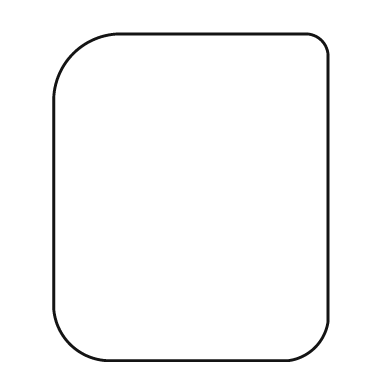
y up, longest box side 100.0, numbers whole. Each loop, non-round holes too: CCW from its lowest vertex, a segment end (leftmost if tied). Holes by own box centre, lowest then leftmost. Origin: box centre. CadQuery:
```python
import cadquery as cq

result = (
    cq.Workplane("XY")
    .moveTo(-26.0, -50.0)
    .lineTo(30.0, -50.0)
    .threePointArc((38.0, -46.0), (42.0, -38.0))
    .lineTo(42.0, 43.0)
    .threePointArc((40.0, 48.0), (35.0, 50.0))
    .lineTo(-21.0, 50.0)
    .threePointArc((-36.0, 44.0), (-42.0, 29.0))
    .lineTo(-42.0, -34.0)
    .threePointArc((-37.0, -45.0), (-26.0, -50.0))
    .close()
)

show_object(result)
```